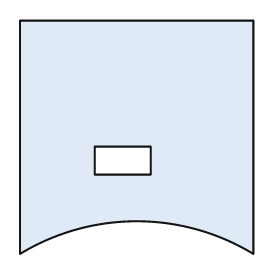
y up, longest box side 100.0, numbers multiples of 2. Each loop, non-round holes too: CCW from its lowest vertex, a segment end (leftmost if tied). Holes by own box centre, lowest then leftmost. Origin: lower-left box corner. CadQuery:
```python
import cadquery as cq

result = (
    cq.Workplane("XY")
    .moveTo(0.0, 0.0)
    .threePointArc((50.0, 14.0), (100.0, 0.0))
    .lineTo(100.0, 100.0)
    .lineTo(0.0, 100.0)
    .close()
    .moveTo(32.0, 34.0)
    .lineTo(56.0, 34.0)
    .lineTo(56.0, 46.0)
    .lineTo(32.0, 46.0)
    .close()
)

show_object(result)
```